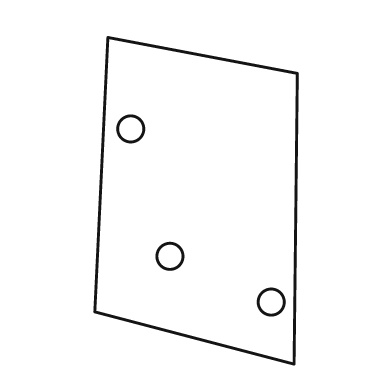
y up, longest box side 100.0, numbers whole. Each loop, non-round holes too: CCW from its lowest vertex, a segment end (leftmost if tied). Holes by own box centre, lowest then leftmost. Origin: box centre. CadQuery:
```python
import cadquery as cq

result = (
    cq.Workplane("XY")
    .moveTo(30.0, -50.0)
    .lineTo(31.0, 39.0)
    .lineTo(-27.0, 50.0)
    .lineTo(-31.0, -34.0)
    .close()
    .moveTo(23.0, -31.0)
    .circle(4.0)
    .moveTo(-8.0, -17.0)
    .circle(4.0)
    .moveTo(-20.0, 22.0)
    .circle(4.0)
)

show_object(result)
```